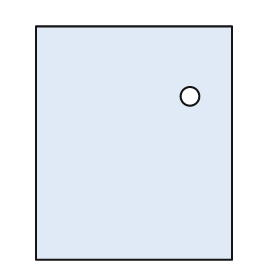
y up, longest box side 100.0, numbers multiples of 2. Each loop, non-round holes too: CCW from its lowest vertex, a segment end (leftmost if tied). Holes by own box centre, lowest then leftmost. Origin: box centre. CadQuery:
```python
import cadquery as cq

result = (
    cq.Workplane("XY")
    .moveTo(-42.0, -50.0)
    .lineTo(42.0, -50.0)
    .lineTo(42.0, 50.0)
    .lineTo(-42.0, 50.0)
    .close()
    .moveTo(24.0, 20.0)
    .circle(4.0)
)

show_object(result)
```